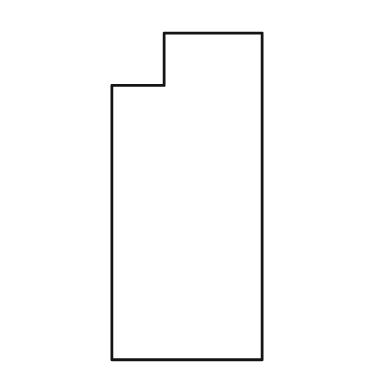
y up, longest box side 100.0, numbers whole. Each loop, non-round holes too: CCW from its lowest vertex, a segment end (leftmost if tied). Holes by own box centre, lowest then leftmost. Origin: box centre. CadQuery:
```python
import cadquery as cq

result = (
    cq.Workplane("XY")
    .moveTo(-23.0, -50.0)
    .lineTo(23.0, -50.0)
    .lineTo(23.0, 50.0)
    .lineTo(-7.0, 50.0)
    .lineTo(-7.0, 34.0)
    .lineTo(-23.0, 34.0)
    .close()
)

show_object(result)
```